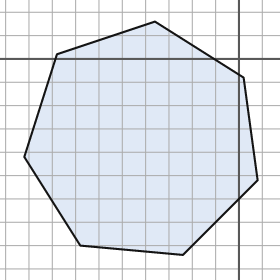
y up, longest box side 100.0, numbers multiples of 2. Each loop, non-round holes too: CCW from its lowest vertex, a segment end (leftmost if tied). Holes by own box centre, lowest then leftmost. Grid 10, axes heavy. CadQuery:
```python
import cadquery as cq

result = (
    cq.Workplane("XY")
    .moveTo(-24.0, -84.0)
    .lineTo(8.0, -52.0)
    .lineTo(2.0, -8.0)
    .lineTo(-36.0, 16.0)
    .lineTo(-78.0, 2.0)
    .lineTo(-92.0, -42.0)
    .lineTo(-68.0, -80.0)
    .close()
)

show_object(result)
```